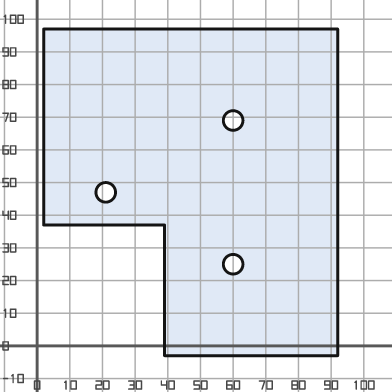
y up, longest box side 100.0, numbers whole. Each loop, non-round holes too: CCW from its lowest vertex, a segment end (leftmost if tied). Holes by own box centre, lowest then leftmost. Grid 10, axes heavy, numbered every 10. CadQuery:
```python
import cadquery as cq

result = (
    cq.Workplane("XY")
    .moveTo(39.0, -3.0)
    .lineTo(92.0, -3.0)
    .lineTo(92.0, 97.0)
    .lineTo(2.0, 97.0)
    .lineTo(2.0, 37.0)
    .lineTo(39.0, 37.0)
    .close()
    .moveTo(60.0, 25.0)
    .circle(3.0)
    .moveTo(21.0, 47.0)
    .circle(3.0)
    .moveTo(60.0, 69.0)
    .circle(3.0)
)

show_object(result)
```